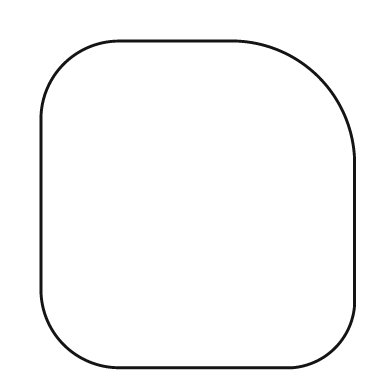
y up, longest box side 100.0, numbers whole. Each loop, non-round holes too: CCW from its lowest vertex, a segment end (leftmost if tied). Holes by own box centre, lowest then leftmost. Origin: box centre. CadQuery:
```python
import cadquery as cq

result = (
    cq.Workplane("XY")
    .moveTo(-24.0, -50.0)
    .lineTo(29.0, -50.0)
    .threePointArc((42.0, -44.0), (48.0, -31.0))
    .lineTo(48.0, 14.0)
    .threePointArc((37.0, 39.0), (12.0, 50.0))
    .lineTo(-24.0, 50.0)
    .threePointArc((-41.0, 43.0), (-48.0, 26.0))
    .lineTo(-48.0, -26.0)
    .threePointArc((-41.0, -43.0), (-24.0, -50.0))
    .close()
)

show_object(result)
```